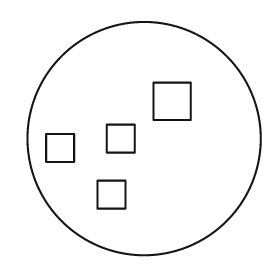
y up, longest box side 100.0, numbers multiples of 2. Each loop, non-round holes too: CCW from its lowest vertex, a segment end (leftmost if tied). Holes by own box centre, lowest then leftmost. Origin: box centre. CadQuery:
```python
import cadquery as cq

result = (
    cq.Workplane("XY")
    .moveTo(0.0, 0.0)
    .circle(50.0)
    .moveTo(-20.0, -30.0)
    .lineTo(-8.0, -30.0)
    .lineTo(-8.0, -18.0)
    .lineTo(-20.0, -18.0)
    .close()
    .moveTo(-42.0, -10.0)
    .lineTo(-30.0, -10.0)
    .lineTo(-30.0, 2.0)
    .lineTo(-42.0, 2.0)
    .close()
    .moveTo(-16.0, -6.0)
    .lineTo(-4.0, -6.0)
    .lineTo(-4.0, 6.0)
    .lineTo(-16.0, 6.0)
    .close()
    .moveTo(4.0, 8.0)
    .lineTo(20.0, 8.0)
    .lineTo(20.0, 24.0)
    .lineTo(4.0, 24.0)
    .close()
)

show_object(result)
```